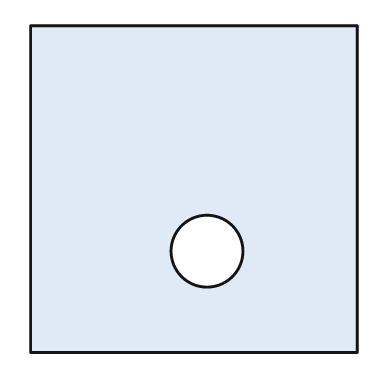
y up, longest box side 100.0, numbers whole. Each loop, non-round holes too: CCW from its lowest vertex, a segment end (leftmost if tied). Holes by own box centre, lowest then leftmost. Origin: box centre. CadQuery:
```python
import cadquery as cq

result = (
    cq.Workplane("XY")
    .moveTo(-50.0, -50.0)
    .lineTo(50.0, -50.0)
    .lineTo(50.0, 50.0)
    .lineTo(-50.0, 50.0)
    .close()
    .moveTo(4.0, -19.0)
    .circle(11.0)
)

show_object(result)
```